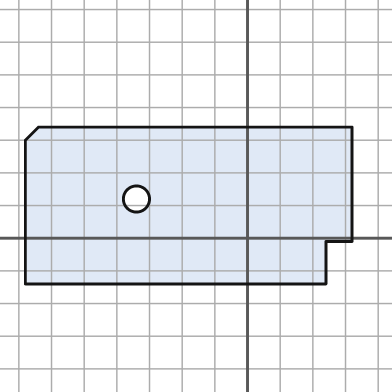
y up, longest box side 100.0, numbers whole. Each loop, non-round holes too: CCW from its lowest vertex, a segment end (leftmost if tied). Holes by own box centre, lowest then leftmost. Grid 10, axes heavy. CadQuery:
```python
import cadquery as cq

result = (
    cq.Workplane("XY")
    .moveTo(-68.0, -14.0)
    .lineTo(24.0, -14.0)
    .lineTo(24.0, -1.0)
    .lineTo(32.0, -1.0)
    .lineTo(32.0, 34.0)
    .lineTo(-64.0, 34.0)
    .lineTo(-68.0, 30.0)
    .close()
    .moveTo(-34.0, 12.0)
    .circle(4.0)
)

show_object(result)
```